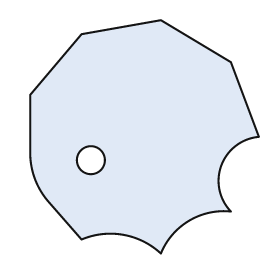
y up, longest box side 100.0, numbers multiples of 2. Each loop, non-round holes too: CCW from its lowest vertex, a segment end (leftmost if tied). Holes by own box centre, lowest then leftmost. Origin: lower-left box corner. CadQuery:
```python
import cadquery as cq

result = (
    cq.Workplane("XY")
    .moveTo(56.0, 0.0)
    .threePointArc((68.0, 14.0), (86.0, 18.0))
    .threePointArc((82.0, 38.0), (98.0, 50.0))
    .lineTo(86.0, 82.0)
    .lineTo(56.0, 100.0)
    .lineTo(22.0, 94.0)
    .lineTo(0.0, 68.0)
    .lineTo(0.0, 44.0)
    .threePointArc((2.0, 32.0), (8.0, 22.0))
    .lineTo(22.0, 6.0)
    .threePointArc((40.0, 8.0), (56.0, 0.0))
    .close()
    .moveTo(26.0, 40.0)
    .circle(6.0)
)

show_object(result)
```